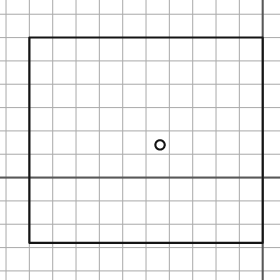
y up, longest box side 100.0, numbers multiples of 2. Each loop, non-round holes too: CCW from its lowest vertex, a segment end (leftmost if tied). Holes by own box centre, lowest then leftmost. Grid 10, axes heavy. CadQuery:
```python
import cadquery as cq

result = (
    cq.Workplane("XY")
    .moveTo(-100.0, -28.0)
    .lineTo(0.0, -28.0)
    .lineTo(0.0, 60.0)
    .lineTo(-100.0, 60.0)
    .close()
    .moveTo(-44.0, 14.0)
    .circle(2.0)
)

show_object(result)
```